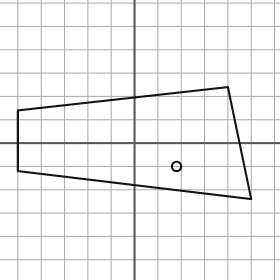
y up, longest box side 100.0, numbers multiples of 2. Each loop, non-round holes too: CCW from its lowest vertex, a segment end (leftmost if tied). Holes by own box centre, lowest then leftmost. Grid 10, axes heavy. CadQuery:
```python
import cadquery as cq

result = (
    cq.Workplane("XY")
    .moveTo(50.0, -24.0)
    .lineTo(40.0, 24.0)
    .lineTo(-50.0, 14.0)
    .lineTo(-50.0, -12.0)
    .close()
    .moveTo(18.0, -10.0)
    .circle(2.0)
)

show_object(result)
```